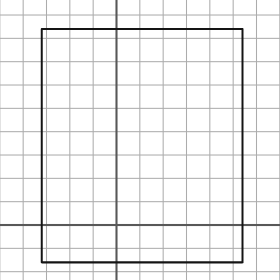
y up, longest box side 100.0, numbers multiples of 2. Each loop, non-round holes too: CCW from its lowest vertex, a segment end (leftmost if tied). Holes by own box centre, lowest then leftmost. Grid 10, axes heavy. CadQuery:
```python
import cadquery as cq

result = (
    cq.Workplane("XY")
    .moveTo(-32.0, -16.0)
    .lineTo(54.0, -16.0)
    .lineTo(54.0, 84.0)
    .lineTo(-32.0, 84.0)
    .close()
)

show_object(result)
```